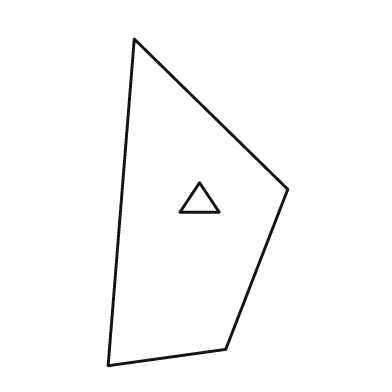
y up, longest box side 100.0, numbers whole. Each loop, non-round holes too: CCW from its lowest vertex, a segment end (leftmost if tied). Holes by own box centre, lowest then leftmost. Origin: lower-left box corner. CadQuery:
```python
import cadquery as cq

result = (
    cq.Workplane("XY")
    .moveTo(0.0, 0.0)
    .lineTo(36.0, 5.0)
    .lineTo(55.0, 54.0)
    .lineTo(8.0, 100.0)
    .close()
    .moveTo(22.0, 47.0)
    .lineTo(34.0, 47.0)
    .lineTo(28.0, 56.0)
    .close()
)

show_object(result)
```